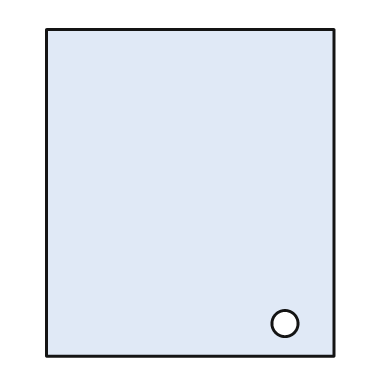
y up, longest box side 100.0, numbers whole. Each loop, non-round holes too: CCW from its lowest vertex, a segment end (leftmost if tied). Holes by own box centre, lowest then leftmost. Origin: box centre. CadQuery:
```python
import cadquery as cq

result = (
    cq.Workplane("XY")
    .moveTo(-44.0, -50.0)
    .lineTo(44.0, -50.0)
    .lineTo(44.0, 50.0)
    .lineTo(-44.0, 50.0)
    .close()
    .moveTo(29.0, -40.0)
    .circle(4.0)
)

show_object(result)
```